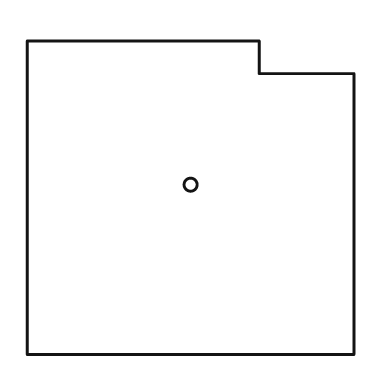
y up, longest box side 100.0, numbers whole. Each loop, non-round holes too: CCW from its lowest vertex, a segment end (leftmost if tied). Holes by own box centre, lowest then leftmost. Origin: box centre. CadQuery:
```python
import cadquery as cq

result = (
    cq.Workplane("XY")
    .moveTo(-50.0, -48.0)
    .lineTo(50.0, -48.0)
    .lineTo(50.0, 38.0)
    .lineTo(21.0, 38.0)
    .lineTo(21.0, 48.0)
    .lineTo(-50.0, 48.0)
    .close()
    .moveTo(0.0, 4.0)
    .circle(2.0)
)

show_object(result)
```